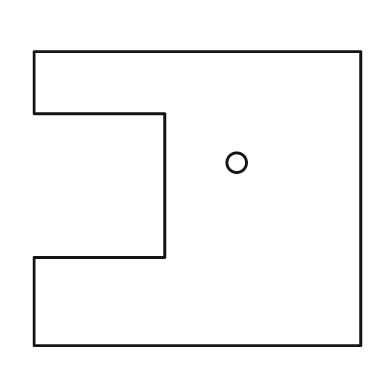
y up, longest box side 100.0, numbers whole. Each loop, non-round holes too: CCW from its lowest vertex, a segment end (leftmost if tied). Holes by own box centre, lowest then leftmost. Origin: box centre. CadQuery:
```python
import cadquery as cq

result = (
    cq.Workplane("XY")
    .moveTo(-50.0, -45.0)
    .lineTo(50.0, -45.0)
    .lineTo(50.0, 45.0)
    .lineTo(-50.0, 45.0)
    .lineTo(-50.0, 26.0)
    .lineTo(-10.0, 26.0)
    .lineTo(-10.0, -18.0)
    .lineTo(-50.0, -18.0)
    .close()
    .moveTo(12.0, 11.0)
    .circle(3.0)
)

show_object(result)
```